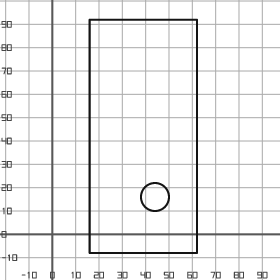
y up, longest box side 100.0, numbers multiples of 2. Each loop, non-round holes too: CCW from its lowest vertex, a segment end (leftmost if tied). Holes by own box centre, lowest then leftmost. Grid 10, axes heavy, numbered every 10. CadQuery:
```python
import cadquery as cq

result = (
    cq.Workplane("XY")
    .moveTo(16.0, -8.0)
    .lineTo(62.0, -8.0)
    .lineTo(62.0, 92.0)
    .lineTo(16.0, 92.0)
    .close()
    .moveTo(44.0, 16.0)
    .circle(6.0)
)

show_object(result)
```